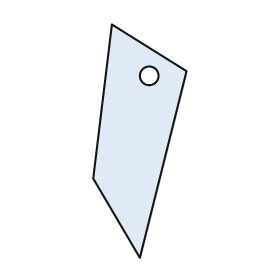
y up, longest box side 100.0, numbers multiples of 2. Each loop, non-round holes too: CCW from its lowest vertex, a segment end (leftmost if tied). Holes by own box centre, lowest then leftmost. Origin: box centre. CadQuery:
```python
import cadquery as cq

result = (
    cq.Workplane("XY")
    .moveTo(0.0, -50.0)
    .lineTo(20.0, 30.0)
    .lineTo(-12.0, 50.0)
    .lineTo(-20.0, -16.0)
    .close()
    .moveTo(4.0, 28.0)
    .circle(4.0)
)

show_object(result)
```